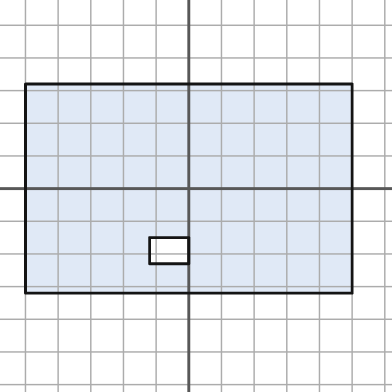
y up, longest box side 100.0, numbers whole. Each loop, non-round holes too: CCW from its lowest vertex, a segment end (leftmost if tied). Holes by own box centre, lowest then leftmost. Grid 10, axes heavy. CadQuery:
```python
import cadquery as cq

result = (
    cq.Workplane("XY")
    .moveTo(-50.0, -32.0)
    .lineTo(50.0, -32.0)
    .lineTo(50.0, 32.0)
    .lineTo(-50.0, 32.0)
    .close()
    .moveTo(-12.0, -23.0)
    .lineTo(0.0, -23.0)
    .lineTo(0.0, -15.0)
    .lineTo(-12.0, -15.0)
    .close()
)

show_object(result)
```